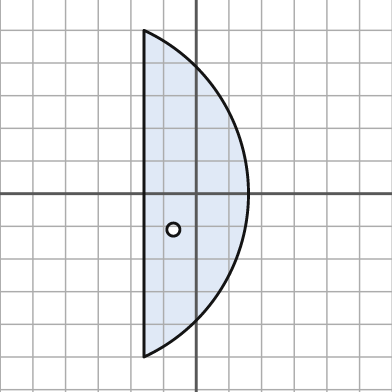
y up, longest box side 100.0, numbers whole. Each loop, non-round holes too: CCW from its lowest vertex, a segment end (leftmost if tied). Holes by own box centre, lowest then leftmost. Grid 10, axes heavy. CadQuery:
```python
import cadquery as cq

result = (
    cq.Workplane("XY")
    .moveTo(-16.0, -50.0)
    .threePointArc((16.0, 0.0), (-16.0, 50.0))
    .close()
    .moveTo(-7.0, -11.0)
    .circle(2.0)
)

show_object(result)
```